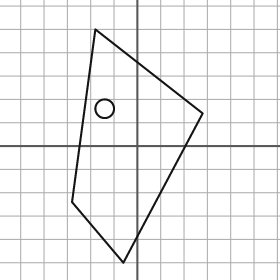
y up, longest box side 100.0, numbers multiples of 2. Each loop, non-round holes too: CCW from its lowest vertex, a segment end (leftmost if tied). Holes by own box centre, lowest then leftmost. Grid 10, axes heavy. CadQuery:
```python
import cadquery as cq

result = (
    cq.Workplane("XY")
    .moveTo(-6.0, -50.0)
    .lineTo(28.0, 14.0)
    .lineTo(-18.0, 50.0)
    .lineTo(-28.0, -24.0)
    .close()
    .moveTo(-14.0, 16.0)
    .circle(4.0)
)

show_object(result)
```